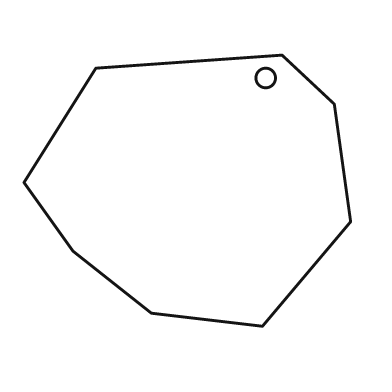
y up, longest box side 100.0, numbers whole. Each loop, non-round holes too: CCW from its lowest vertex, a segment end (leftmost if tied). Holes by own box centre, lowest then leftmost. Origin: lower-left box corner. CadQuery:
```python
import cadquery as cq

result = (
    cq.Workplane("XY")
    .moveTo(73.0, 0.0)
    .lineTo(100.0, 32.0)
    .lineTo(95.0, 68.0)
    .lineTo(79.0, 83.0)
    .lineTo(22.0, 79.0)
    .lineTo(0.0, 44.0)
    .lineTo(15.0, 23.0)
    .lineTo(39.0, 4.0)
    .close()
    .moveTo(74.0, 76.0)
    .circle(3.0)
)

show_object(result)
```